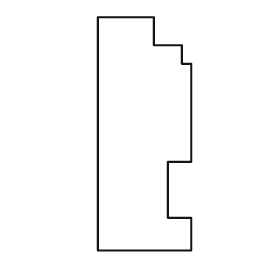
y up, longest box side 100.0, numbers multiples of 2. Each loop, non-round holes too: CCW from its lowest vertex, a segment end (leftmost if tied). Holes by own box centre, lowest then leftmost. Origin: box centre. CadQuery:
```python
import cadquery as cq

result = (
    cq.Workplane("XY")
    .moveTo(-20.0, -50.0)
    .lineTo(20.0, -50.0)
    .lineTo(20.0, -36.0)
    .lineTo(10.0, -36.0)
    .lineTo(10.0, -12.0)
    .lineTo(20.0, -12.0)
    .lineTo(20.0, 30.0)
    .lineTo(16.0, 30.0)
    .lineTo(16.0, 38.0)
    .lineTo(4.0, 38.0)
    .lineTo(4.0, 50.0)
    .lineTo(-20.0, 50.0)
    .close()
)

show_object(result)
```